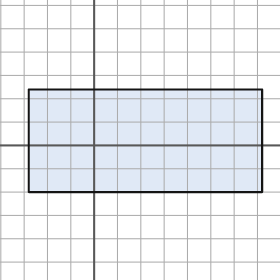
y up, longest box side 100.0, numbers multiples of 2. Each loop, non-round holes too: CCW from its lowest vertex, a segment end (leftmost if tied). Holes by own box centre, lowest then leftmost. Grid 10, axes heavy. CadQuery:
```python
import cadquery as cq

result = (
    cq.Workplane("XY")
    .moveTo(-28.0, -20.0)
    .lineTo(72.0, -20.0)
    .lineTo(72.0, 24.0)
    .lineTo(-28.0, 24.0)
    .close()
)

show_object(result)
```